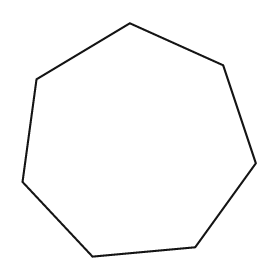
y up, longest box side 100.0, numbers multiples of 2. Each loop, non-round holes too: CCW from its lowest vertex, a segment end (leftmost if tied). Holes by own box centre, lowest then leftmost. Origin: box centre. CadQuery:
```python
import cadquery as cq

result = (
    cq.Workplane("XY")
    .moveTo(-20.0, -50.0)
    .lineTo(24.0, -46.0)
    .lineTo(50.0, -10.0)
    .lineTo(36.0, 32.0)
    .lineTo(-4.0, 50.0)
    .lineTo(-44.0, 26.0)
    .lineTo(-50.0, -18.0)
    .close()
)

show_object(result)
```